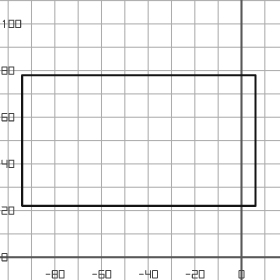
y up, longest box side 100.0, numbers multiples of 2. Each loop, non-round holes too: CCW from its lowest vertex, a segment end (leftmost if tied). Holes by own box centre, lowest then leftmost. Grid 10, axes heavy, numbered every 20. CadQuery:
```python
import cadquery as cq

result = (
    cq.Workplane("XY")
    .moveTo(-94.0, 22.0)
    .lineTo(6.0, 22.0)
    .lineTo(6.0, 78.0)
    .lineTo(-94.0, 78.0)
    .close()
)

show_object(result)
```